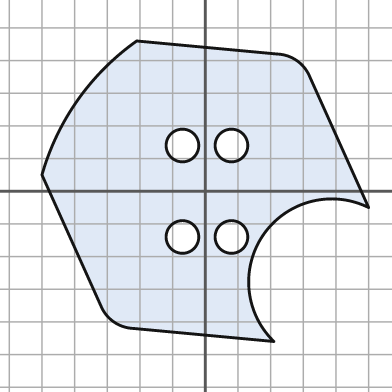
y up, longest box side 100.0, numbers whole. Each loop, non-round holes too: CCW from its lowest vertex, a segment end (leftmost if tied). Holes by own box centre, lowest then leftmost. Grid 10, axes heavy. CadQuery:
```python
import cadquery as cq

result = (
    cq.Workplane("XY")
    .moveTo(21.0, -46.0)
    .threePointArc((18.0, -13.0), (50.0, -5.0))
    .lineTo(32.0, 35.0)
    .threePointArc((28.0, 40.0), (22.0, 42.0))
    .lineTo(-21.0, 46.0)
    .threePointArc((-39.0, 28.0), (-50.0, 5.0))
    .lineTo(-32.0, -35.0)
    .threePointArc((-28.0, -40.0), (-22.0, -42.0))
    .close()
    .moveTo(-7.0, -14.0)
    .circle(5.0)
    .moveTo(8.0, -14.0)
    .circle(5.0)
    .moveTo(-7.0, 14.0)
    .circle(5.0)
    .moveTo(8.0, 14.0)
    .circle(5.0)
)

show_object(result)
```